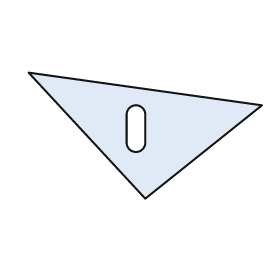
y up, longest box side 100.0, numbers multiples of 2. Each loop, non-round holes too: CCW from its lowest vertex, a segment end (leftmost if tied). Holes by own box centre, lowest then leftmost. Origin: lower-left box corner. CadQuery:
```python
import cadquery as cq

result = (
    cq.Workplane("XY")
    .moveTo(50.0, 0.0)
    .lineTo(100.0, 40.0)
    .lineTo(0.0, 54.0)
    .close()
    .moveTo(42.0, 24.0)
    .threePointArc((46.0, 20.0), (50.0, 24.0))
    .lineTo(50.0, 36.0)
    .threePointArc((46.0, 40.0), (42.0, 36.0))
    .close()
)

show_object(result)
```